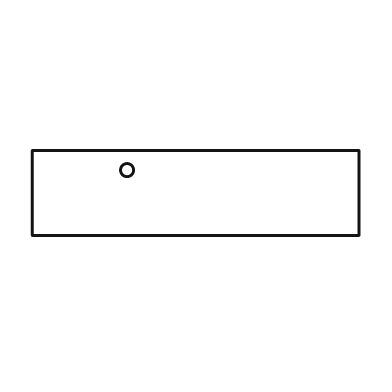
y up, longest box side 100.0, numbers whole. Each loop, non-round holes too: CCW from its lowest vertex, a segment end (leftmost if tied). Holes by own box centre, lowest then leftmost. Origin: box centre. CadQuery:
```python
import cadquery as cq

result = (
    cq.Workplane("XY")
    .moveTo(-50.0, -13.0)
    .lineTo(50.0, -13.0)
    .lineTo(50.0, 13.0)
    .lineTo(-50.0, 13.0)
    .close()
    .moveTo(-21.0, 7.0)
    .circle(2.0)
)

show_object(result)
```